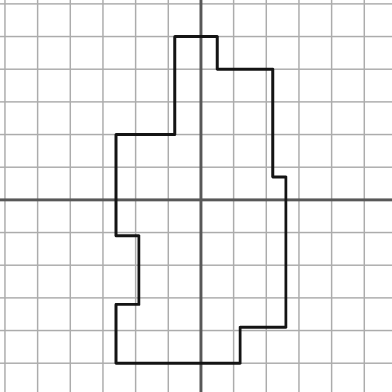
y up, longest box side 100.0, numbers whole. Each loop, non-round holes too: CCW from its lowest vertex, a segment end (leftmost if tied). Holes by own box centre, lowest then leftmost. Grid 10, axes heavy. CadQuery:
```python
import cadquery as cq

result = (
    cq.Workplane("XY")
    .moveTo(-26.0, -50.0)
    .lineTo(12.0, -50.0)
    .lineTo(12.0, -39.0)
    .lineTo(26.0, -39.0)
    .lineTo(26.0, 7.0)
    .lineTo(22.0, 7.0)
    .lineTo(22.0, 40.0)
    .lineTo(5.0, 40.0)
    .lineTo(5.0, 50.0)
    .lineTo(-8.0, 50.0)
    .lineTo(-8.0, 20.0)
    .lineTo(-26.0, 20.0)
    .lineTo(-26.0, -11.0)
    .lineTo(-19.0, -11.0)
    .lineTo(-19.0, -32.0)
    .lineTo(-26.0, -32.0)
    .close()
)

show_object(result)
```